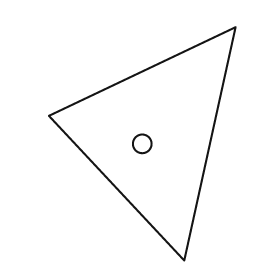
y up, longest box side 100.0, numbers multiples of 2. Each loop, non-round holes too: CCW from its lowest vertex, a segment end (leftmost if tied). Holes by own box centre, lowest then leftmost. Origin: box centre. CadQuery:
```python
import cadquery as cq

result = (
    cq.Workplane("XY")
    .moveTo(18.0, -50.0)
    .lineTo(40.0, 50.0)
    .lineTo(-40.0, 12.0)
    .close()
    .moveTo(0.0, 0.0)
    .circle(4.0)
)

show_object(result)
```